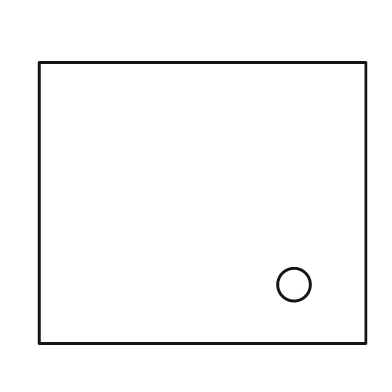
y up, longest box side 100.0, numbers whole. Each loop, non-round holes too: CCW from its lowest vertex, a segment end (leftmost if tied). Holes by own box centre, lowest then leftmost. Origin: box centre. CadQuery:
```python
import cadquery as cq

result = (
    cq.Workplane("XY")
    .moveTo(-50.0, -43.0)
    .lineTo(50.0, -43.0)
    .lineTo(50.0, 43.0)
    .lineTo(-50.0, 43.0)
    .close()
    .moveTo(28.0, -25.0)
    .circle(5.0)
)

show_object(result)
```